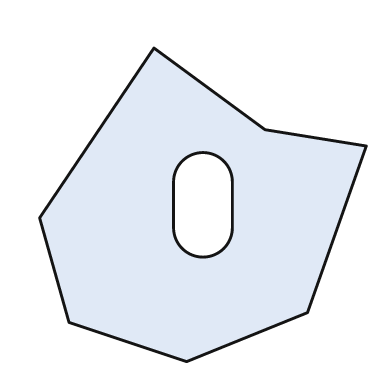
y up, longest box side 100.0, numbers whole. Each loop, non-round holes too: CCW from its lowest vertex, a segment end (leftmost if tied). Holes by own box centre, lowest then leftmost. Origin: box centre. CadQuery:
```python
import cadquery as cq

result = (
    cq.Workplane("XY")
    .moveTo(-5.0, -48.0)
    .lineTo(32.0, -33.0)
    .lineTo(50.0, 18.0)
    .lineTo(19.0, 23.0)
    .lineTo(-15.0, 48.0)
    .lineTo(-50.0, -4.0)
    .lineTo(-41.0, -36.0)
    .close()
    .moveTo(-9.0, -7.0)
    .threePointArc((0.0, -16.0), (9.0, -7.0))
    .lineTo(9.0, 7.0)
    .threePointArc((0.0, 16.0), (-9.0, 7.0))
    .close()
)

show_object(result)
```